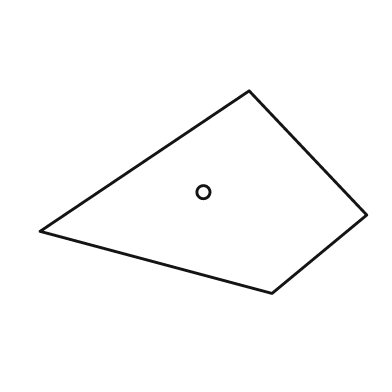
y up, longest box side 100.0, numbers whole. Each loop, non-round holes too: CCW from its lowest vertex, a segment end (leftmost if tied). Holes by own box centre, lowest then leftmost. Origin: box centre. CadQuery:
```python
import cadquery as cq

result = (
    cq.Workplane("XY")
    .moveTo(21.0, -31.0)
    .lineTo(50.0, -7.0)
    .lineTo(14.0, 31.0)
    .lineTo(-50.0, -12.0)
    .close()
    .moveTo(0.0, 0.0)
    .circle(2.0)
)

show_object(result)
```